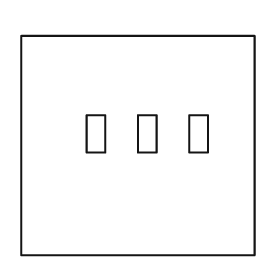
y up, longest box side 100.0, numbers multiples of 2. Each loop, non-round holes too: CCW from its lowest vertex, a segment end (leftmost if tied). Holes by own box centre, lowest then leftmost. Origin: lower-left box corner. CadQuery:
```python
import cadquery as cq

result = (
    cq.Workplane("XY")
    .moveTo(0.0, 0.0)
    .lineTo(100.0, 0.0)
    .lineTo(100.0, 94.0)
    .lineTo(0.0, 94.0)
    .close()
    .moveTo(28.0, 44.0)
    .lineTo(36.0, 44.0)
    .lineTo(36.0, 60.0)
    .lineTo(28.0, 60.0)
    .close()
    .moveTo(50.0, 44.0)
    .lineTo(58.0, 44.0)
    .lineTo(58.0, 60.0)
    .lineTo(50.0, 60.0)
    .close()
    .moveTo(72.0, 44.0)
    .lineTo(80.0, 44.0)
    .lineTo(80.0, 60.0)
    .lineTo(72.0, 60.0)
    .close()
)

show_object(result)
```